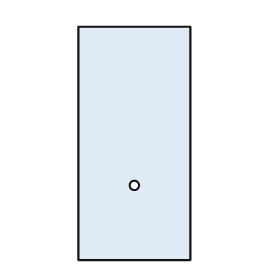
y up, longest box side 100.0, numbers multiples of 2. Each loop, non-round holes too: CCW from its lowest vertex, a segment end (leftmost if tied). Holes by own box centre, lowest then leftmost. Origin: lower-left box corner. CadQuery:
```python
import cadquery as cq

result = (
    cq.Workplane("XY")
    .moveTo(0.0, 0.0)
    .lineTo(48.0, 0.0)
    .lineTo(48.0, 100.0)
    .lineTo(0.0, 100.0)
    .close()
    .moveTo(24.0, 32.0)
    .circle(2.0)
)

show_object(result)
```